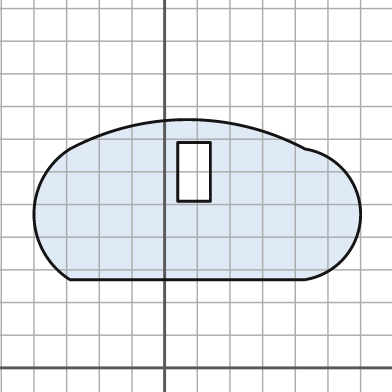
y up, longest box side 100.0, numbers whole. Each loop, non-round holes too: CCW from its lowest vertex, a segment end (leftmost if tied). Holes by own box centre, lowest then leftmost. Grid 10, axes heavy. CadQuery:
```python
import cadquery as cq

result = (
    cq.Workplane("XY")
    .moveTo(-29.0, 27.0)
    .lineTo(43.0, 27.0)
    .threePointArc((60.0, 47.0), (43.0, 67.0))
    .threePointArc((7.0, 76.0), (-29.0, 67.0))
    .threePointArc((-40.0, 47.0), (-29.0, 27.0))
    .close()
    .moveTo(4.0, 51.0)
    .lineTo(14.0, 51.0)
    .lineTo(14.0, 69.0)
    .lineTo(4.0, 69.0)
    .close()
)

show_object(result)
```